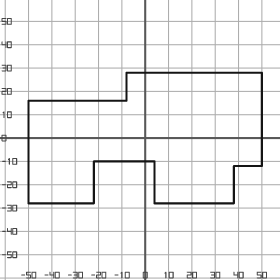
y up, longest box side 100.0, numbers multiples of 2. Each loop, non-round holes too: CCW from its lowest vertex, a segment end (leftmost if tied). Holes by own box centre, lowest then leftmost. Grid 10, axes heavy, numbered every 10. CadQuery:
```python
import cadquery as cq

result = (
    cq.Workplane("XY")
    .moveTo(-50.0, -28.0)
    .lineTo(-22.0, -28.0)
    .lineTo(-22.0, -10.0)
    .lineTo(4.0, -10.0)
    .lineTo(4.0, -28.0)
    .lineTo(38.0, -28.0)
    .lineTo(38.0, -12.0)
    .lineTo(50.0, -12.0)
    .lineTo(50.0, 28.0)
    .lineTo(-8.0, 28.0)
    .lineTo(-8.0, 16.0)
    .lineTo(-50.0, 16.0)
    .close()
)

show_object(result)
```